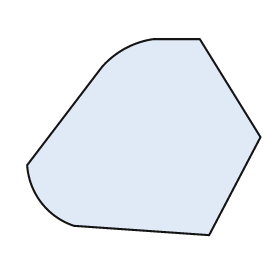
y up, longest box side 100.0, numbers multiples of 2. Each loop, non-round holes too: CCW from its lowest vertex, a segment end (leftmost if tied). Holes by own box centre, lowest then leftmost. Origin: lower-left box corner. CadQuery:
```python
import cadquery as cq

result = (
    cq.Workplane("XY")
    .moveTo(78.0, 0.0)
    .lineTo(100.0, 42.0)
    .lineTo(74.0, 84.0)
    .lineTo(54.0, 84.0)
    .threePointArc((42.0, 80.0), (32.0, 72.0))
    .lineTo(0.0, 30.0)
    .threePointArc((6.0, 14.0), (20.0, 4.0))
    .close()
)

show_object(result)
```